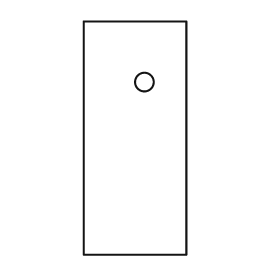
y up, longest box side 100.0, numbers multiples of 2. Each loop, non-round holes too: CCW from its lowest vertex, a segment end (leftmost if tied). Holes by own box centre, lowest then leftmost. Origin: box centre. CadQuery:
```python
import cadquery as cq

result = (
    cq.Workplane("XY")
    .moveTo(-22.0, -50.0)
    .lineTo(22.0, -50.0)
    .lineTo(22.0, 50.0)
    .lineTo(-22.0, 50.0)
    .close()
    .moveTo(4.0, 24.0)
    .circle(4.0)
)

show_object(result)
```